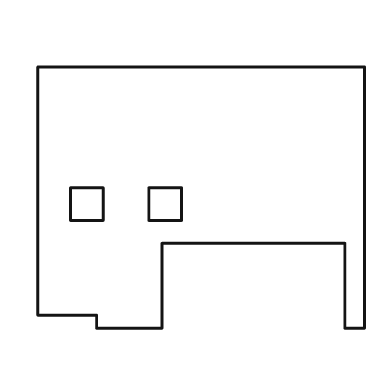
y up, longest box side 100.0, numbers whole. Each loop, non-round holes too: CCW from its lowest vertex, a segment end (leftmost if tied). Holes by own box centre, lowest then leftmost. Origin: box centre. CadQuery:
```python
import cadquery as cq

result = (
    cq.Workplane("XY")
    .moveTo(-32.0, -40.0)
    .lineTo(-12.0, -40.0)
    .lineTo(-12.0, -14.0)
    .lineTo(44.0, -14.0)
    .lineTo(44.0, -40.0)
    .lineTo(50.0, -40.0)
    .lineTo(50.0, 40.0)
    .lineTo(-50.0, 40.0)
    .lineTo(-50.0, -36.0)
    .lineTo(-32.0, -36.0)
    .close()
    .moveTo(-40.0, -7.0)
    .lineTo(-30.0, -7.0)
    .lineTo(-30.0, 3.0)
    .lineTo(-40.0, 3.0)
    .close()
    .moveTo(-16.0, -7.0)
    .lineTo(-6.0, -7.0)
    .lineTo(-6.0, 3.0)
    .lineTo(-16.0, 3.0)
    .close()
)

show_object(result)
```